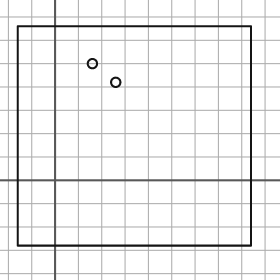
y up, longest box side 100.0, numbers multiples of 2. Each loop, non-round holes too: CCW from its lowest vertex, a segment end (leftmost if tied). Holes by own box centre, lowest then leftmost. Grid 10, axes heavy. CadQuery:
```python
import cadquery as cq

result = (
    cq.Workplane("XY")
    .moveTo(-16.0, -28.0)
    .lineTo(84.0, -28.0)
    .lineTo(84.0, 66.0)
    .lineTo(-16.0, 66.0)
    .close()
    .moveTo(26.0, 42.0)
    .circle(2.0)
    .moveTo(16.0, 50.0)
    .circle(2.0)
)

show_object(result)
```